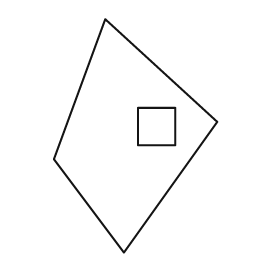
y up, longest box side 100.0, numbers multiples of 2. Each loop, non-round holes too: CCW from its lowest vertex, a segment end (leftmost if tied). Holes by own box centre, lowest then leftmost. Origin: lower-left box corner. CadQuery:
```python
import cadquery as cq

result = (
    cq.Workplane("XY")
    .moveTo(30.0, 0.0)
    .lineTo(70.0, 56.0)
    .lineTo(22.0, 100.0)
    .lineTo(0.0, 40.0)
    .close()
    .moveTo(36.0, 46.0)
    .lineTo(52.0, 46.0)
    .lineTo(52.0, 62.0)
    .lineTo(36.0, 62.0)
    .close()
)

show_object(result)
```